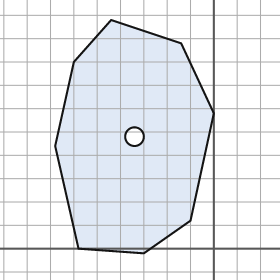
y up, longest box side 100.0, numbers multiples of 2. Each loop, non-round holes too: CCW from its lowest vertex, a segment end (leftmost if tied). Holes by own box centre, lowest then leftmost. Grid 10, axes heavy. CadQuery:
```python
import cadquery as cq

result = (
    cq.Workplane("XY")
    .moveTo(-30.0, -2.0)
    .lineTo(-10.0, 12.0)
    .lineTo(0.0, 58.0)
    .lineTo(-14.0, 88.0)
    .lineTo(-44.0, 98.0)
    .lineTo(-60.0, 80.0)
    .lineTo(-68.0, 44.0)
    .lineTo(-58.0, 0.0)
    .close()
    .moveTo(-34.0, 48.0)
    .circle(4.0)
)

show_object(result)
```